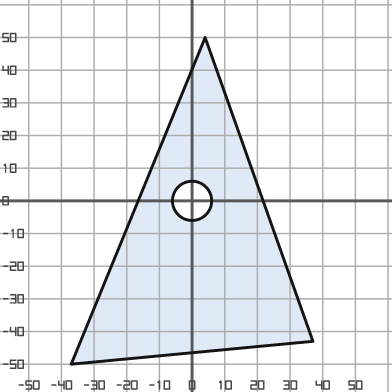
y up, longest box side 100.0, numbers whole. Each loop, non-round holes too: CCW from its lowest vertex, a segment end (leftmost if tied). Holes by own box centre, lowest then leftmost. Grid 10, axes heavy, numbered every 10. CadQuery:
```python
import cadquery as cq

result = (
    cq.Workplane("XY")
    .moveTo(-37.0, -50.0)
    .lineTo(37.0, -43.0)
    .lineTo(4.0, 50.0)
    .close()
    .moveTo(0.0, 0.0)
    .circle(6.0)
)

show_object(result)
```